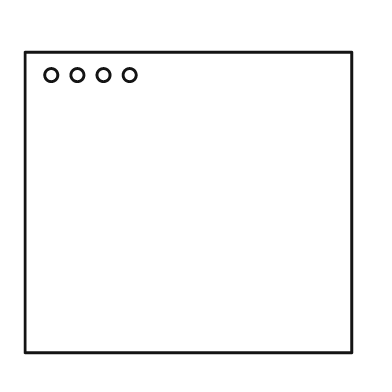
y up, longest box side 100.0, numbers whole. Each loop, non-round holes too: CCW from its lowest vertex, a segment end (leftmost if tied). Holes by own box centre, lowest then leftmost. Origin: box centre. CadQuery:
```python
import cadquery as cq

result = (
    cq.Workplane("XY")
    .moveTo(-50.0, -46.0)
    .lineTo(50.0, -46.0)
    .lineTo(50.0, 46.0)
    .lineTo(-50.0, 46.0)
    .close()
    .moveTo(-42.0, 39.0)
    .circle(2.0)
    .moveTo(-34.0, 39.0)
    .circle(2.0)
    .moveTo(-26.0, 39.0)
    .circle(2.0)
    .moveTo(-18.0, 39.0)
    .circle(2.0)
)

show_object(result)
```